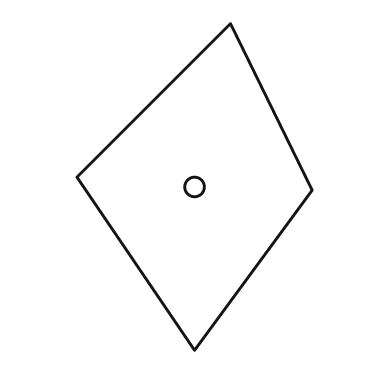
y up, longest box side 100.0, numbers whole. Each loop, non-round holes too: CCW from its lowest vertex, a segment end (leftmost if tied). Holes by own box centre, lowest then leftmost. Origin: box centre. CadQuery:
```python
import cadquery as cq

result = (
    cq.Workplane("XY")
    .moveTo(0.0, -50.0)
    .lineTo(36.0, -1.0)
    .lineTo(11.0, 50.0)
    .lineTo(-36.0, 3.0)
    .close()
    .moveTo(0.0, 0.0)
    .circle(3.0)
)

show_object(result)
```